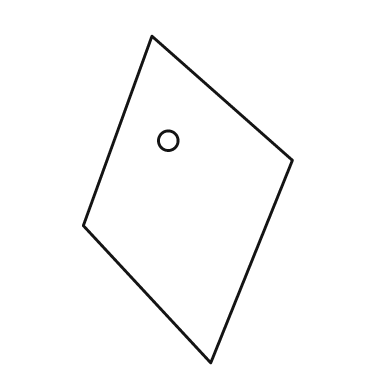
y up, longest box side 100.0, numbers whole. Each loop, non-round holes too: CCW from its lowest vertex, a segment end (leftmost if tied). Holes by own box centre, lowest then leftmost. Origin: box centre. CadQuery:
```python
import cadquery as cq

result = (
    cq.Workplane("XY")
    .moveTo(7.0, -50.0)
    .lineTo(32.0, 12.0)
    .lineTo(-11.0, 50.0)
    .lineTo(-32.0, -8.0)
    .close()
    .moveTo(-6.0, 18.0)
    .circle(3.0)
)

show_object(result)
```